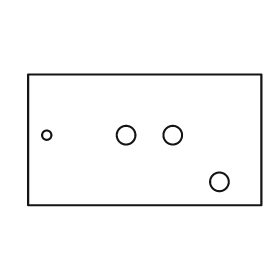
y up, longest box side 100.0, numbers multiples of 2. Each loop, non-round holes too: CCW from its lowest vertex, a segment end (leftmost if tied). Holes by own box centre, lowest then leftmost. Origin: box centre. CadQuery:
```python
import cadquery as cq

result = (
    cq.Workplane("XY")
    .moveTo(-50.0, -28.0)
    .lineTo(50.0, -28.0)
    .lineTo(50.0, 28.0)
    .lineTo(-50.0, 28.0)
    .close()
    .moveTo(32.0, -18.0)
    .circle(4.0)
    .moveTo(-42.0, 2.0)
    .circle(2.0)
    .moveTo(-8.0, 2.0)
    .circle(4.0)
    .moveTo(12.0, 2.0)
    .circle(4.0)
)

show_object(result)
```